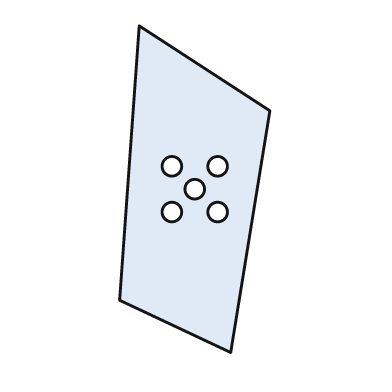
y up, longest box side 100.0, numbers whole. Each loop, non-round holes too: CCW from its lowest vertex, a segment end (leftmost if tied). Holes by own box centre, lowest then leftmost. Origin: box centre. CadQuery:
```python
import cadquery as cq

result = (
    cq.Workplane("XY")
    .moveTo(11.0, -50.0)
    .lineTo(23.0, 24.0)
    .lineTo(-17.0, 50.0)
    .lineTo(-23.0, -34.0)
    .close()
    .moveTo(-7.0, -7.0)
    .circle(3.0)
    .moveTo(7.0, -7.0)
    .circle(3.0)
    .moveTo(0.0, 0.0)
    .circle(3.0)
    .moveTo(-7.0, 7.0)
    .circle(3.0)
    .moveTo(7.0, 7.0)
    .circle(3.0)
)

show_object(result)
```